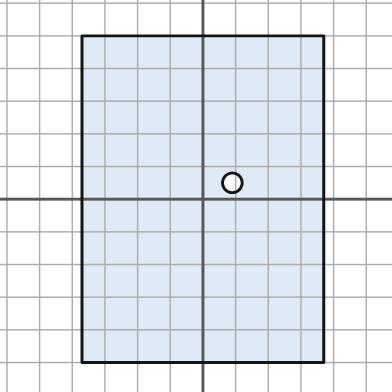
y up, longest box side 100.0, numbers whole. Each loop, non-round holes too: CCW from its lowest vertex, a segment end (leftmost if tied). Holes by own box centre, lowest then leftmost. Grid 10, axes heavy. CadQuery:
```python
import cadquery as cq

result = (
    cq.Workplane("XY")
    .moveTo(-37.0, -50.0)
    .lineTo(37.0, -50.0)
    .lineTo(37.0, 50.0)
    .lineTo(-37.0, 50.0)
    .close()
    .moveTo(9.0, 5.0)
    .circle(3.0)
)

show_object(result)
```